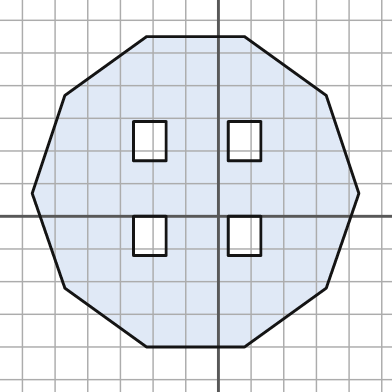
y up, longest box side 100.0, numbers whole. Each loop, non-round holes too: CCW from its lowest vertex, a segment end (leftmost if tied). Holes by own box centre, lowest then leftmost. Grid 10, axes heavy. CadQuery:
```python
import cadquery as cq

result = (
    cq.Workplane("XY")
    .moveTo(-22.0, -40.0)
    .lineTo(8.0, -40.0)
    .lineTo(33.0, -22.0)
    .lineTo(43.0, 7.0)
    .lineTo(33.0, 37.0)
    .lineTo(8.0, 55.0)
    .lineTo(-22.0, 55.0)
    .lineTo(-47.0, 37.0)
    .lineTo(-57.0, 7.0)
    .lineTo(-47.0, -22.0)
    .close()
    .moveTo(-26.0, -12.0)
    .lineTo(-16.0, -12.0)
    .lineTo(-16.0, 0.0)
    .lineTo(-26.0, 0.0)
    .close()
    .moveTo(3.0, -12.0)
    .lineTo(13.0, -12.0)
    .lineTo(13.0, 0.0)
    .lineTo(3.0, 0.0)
    .close()
    .moveTo(-26.0, 17.0)
    .lineTo(-16.0, 17.0)
    .lineTo(-16.0, 29.0)
    .lineTo(-26.0, 29.0)
    .close()
    .moveTo(3.0, 17.0)
    .lineTo(13.0, 17.0)
    .lineTo(13.0, 29.0)
    .lineTo(3.0, 29.0)
    .close()
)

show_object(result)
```